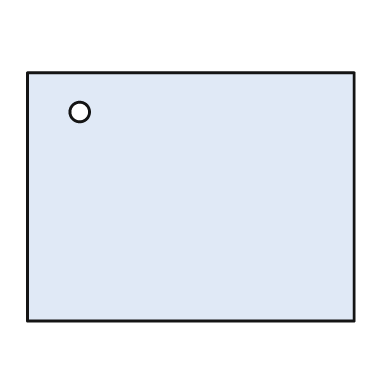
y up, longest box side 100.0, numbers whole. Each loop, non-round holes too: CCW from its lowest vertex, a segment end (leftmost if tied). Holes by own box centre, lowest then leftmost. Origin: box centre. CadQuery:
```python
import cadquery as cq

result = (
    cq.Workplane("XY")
    .moveTo(-50.0, -38.0)
    .lineTo(50.0, -38.0)
    .lineTo(50.0, 38.0)
    .lineTo(-50.0, 38.0)
    .close()
    .moveTo(-34.0, 26.0)
    .circle(3.0)
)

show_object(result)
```